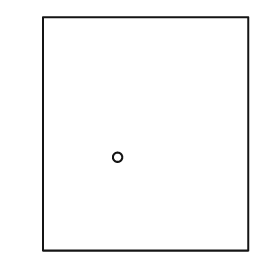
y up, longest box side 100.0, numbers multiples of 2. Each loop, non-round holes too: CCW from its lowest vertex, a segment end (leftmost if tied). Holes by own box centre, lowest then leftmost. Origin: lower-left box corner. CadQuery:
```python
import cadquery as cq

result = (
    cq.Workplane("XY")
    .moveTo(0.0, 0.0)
    .lineTo(88.0, 0.0)
    .lineTo(88.0, 100.0)
    .lineTo(0.0, 100.0)
    .close()
    .moveTo(32.0, 40.0)
    .circle(2.0)
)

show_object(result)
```